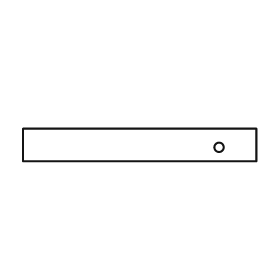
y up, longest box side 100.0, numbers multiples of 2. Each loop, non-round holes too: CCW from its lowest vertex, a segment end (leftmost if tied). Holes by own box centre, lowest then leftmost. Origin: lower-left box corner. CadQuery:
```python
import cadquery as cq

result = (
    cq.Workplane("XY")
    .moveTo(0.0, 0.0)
    .lineTo(100.0, 0.0)
    .lineTo(100.0, 14.0)
    .lineTo(0.0, 14.0)
    .close()
    .moveTo(84.0, 6.0)
    .circle(2.0)
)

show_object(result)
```